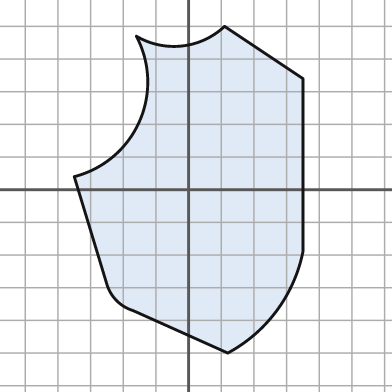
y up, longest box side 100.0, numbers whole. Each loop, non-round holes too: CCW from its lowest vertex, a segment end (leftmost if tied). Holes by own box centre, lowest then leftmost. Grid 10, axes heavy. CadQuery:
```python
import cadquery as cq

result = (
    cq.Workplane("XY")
    .moveTo(12.0, -50.0)
    .threePointArc((27.0, -37.0), (35.0, -19.0))
    .lineTo(35.0, 34.0)
    .lineTo(11.0, 50.0)
    .threePointArc((-2.0, 44.0), (-16.0, 47.0))
    .threePointArc((-15.0, 21.0), (-35.0, 4.0))
    .lineTo(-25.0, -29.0)
    .threePointArc((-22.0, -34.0), (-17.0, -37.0))
    .close()
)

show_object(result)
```